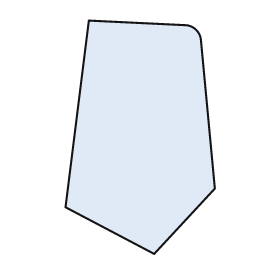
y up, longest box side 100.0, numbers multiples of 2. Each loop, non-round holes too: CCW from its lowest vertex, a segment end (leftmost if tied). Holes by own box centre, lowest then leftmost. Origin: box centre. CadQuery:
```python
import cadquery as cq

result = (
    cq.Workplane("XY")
    .moveTo(6.0, -50.0)
    .lineTo(32.0, -22.0)
    .lineTo(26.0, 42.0)
    .threePointArc((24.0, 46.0), (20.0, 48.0))
    .lineTo(-22.0, 50.0)
    .lineTo(-32.0, -30.0)
    .close()
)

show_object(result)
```